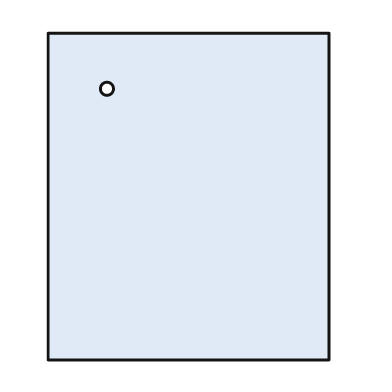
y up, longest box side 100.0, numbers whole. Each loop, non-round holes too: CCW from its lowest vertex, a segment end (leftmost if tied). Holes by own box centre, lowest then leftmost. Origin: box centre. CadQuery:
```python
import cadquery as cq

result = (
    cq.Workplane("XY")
    .moveTo(-43.0, -50.0)
    .lineTo(43.0, -50.0)
    .lineTo(43.0, 50.0)
    .lineTo(-43.0, 50.0)
    .close()
    .moveTo(-25.0, 33.0)
    .circle(2.0)
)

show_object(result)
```